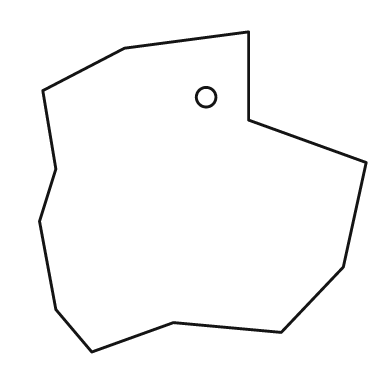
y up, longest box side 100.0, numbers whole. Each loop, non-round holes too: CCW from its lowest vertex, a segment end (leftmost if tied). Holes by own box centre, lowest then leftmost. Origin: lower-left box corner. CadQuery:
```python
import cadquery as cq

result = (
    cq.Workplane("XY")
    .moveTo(16.0, 0.0)
    .lineTo(41.0, 9.0)
    .lineTo(74.0, 6.0)
    .lineTo(93.0, 26.0)
    .lineTo(100.0, 58.0)
    .lineTo(64.0, 71.0)
    .lineTo(64.0, 98.0)
    .lineTo(26.0, 93.0)
    .lineTo(1.0, 80.0)
    .lineTo(5.0, 56.0)
    .lineTo(0.0, 40.0)
    .lineTo(5.0, 13.0)
    .close()
    .moveTo(51.0, 78.0)
    .circle(3.0)
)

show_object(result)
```